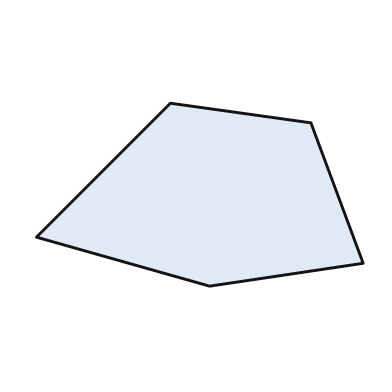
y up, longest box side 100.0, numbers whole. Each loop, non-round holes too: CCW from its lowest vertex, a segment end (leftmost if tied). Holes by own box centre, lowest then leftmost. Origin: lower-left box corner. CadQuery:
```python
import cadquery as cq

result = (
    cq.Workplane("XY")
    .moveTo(53.0, 0.0)
    .lineTo(100.0, 7.0)
    .lineTo(84.0, 50.0)
    .lineTo(41.0, 56.0)
    .lineTo(0.0, 15.0)
    .close()
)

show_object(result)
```